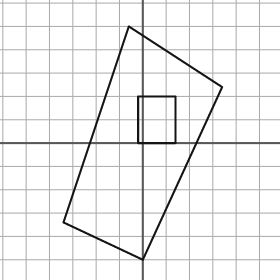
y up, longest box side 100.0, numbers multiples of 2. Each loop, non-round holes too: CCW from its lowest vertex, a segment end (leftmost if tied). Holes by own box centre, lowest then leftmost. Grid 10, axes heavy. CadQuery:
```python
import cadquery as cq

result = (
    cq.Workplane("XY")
    .moveTo(0.0, -50.0)
    .lineTo(34.0, 24.0)
    .lineTo(-6.0, 50.0)
    .lineTo(-34.0, -34.0)
    .close()
    .moveTo(-2.0, 0.0)
    .lineTo(14.0, 0.0)
    .lineTo(14.0, 20.0)
    .lineTo(-2.0, 20.0)
    .close()
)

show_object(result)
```